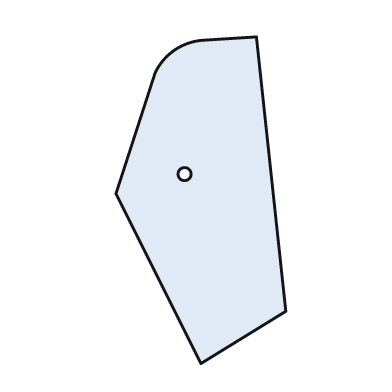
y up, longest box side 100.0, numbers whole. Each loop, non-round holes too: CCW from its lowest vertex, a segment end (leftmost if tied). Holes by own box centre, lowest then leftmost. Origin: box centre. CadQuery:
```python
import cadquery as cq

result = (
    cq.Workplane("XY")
    .moveTo(0.0, -50.0)
    .lineTo(26.0, -34.0)
    .lineTo(17.0, 50.0)
    .lineTo(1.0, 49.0)
    .threePointArc((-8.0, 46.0), (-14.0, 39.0))
    .lineTo(-26.0, 2.0)
    .close()
    .moveTo(-5.0, 8.0)
    .circle(2.0)
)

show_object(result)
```